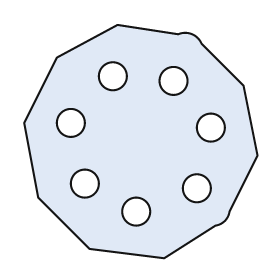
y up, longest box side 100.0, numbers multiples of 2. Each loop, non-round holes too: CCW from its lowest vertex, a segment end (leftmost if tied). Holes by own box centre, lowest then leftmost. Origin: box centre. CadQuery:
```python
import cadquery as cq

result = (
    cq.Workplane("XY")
    .moveTo(10.0, -50.0)
    .lineTo(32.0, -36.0)
    .threePointArc((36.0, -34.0), (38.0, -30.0))
    .lineTo(50.0, -6.0)
    .lineTo(44.0, 24.0)
    .lineTo(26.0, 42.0)
    .threePointArc((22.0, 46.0), (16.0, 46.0))
    .lineTo(-10.0, 50.0)
    .lineTo(-36.0, 36.0)
    .lineTo(-50.0, 8.0)
    .lineTo(-44.0, -24.0)
    .lineTo(-22.0, -46.0)
    .close()
    .moveTo(-2.0, -30.0)
    .circle(6.0)
    .moveTo(24.0, -20.0)
    .circle(6.0)
    .moveTo(-24.0, -18.0)
    .circle(6.0)
    .moveTo(30.0, 6.0)
    .circle(6.0)
    .moveTo(-30.0, 8.0)
    .circle(6.0)
    .moveTo(14.0, 26.0)
    .circle(6.0)
    .moveTo(-12.0, 28.0)
    .circle(6.0)
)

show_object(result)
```